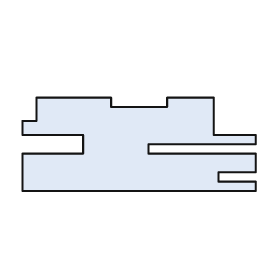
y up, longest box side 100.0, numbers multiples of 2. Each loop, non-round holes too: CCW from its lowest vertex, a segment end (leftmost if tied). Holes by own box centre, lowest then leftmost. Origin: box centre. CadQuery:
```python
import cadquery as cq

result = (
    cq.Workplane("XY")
    .moveTo(-50.0, -20.0)
    .lineTo(50.0, -20.0)
    .lineTo(50.0, -16.0)
    .lineTo(34.0, -16.0)
    .lineTo(34.0, -12.0)
    .lineTo(50.0, -12.0)
    .lineTo(50.0, -4.0)
    .lineTo(4.0, -4.0)
    .lineTo(4.0, 0.0)
    .lineTo(50.0, 0.0)
    .lineTo(50.0, 4.0)
    .lineTo(32.0, 4.0)
    .lineTo(32.0, 20.0)
    .lineTo(12.0, 20.0)
    .lineTo(12.0, 16.0)
    .lineTo(-12.0, 16.0)
    .lineTo(-12.0, 20.0)
    .lineTo(-44.0, 20.0)
    .lineTo(-44.0, 10.0)
    .lineTo(-50.0, 10.0)
    .lineTo(-50.0, 4.0)
    .lineTo(-24.0, 4.0)
    .lineTo(-24.0, -4.0)
    .lineTo(-50.0, -4.0)
    .close()
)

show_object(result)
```